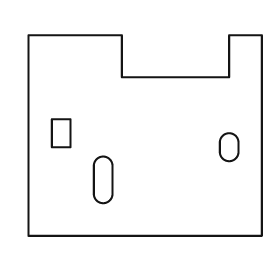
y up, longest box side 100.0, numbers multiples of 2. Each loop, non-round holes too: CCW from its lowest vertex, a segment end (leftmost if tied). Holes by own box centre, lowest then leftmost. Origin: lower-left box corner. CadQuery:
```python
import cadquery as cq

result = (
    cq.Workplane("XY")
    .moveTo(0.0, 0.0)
    .lineTo(100.0, 0.0)
    .lineTo(100.0, 86.0)
    .lineTo(86.0, 86.0)
    .lineTo(86.0, 68.0)
    .lineTo(40.0, 68.0)
    .lineTo(40.0, 86.0)
    .lineTo(0.0, 86.0)
    .close()
    .moveTo(28.0, 18.0)
    .threePointArc((32.0, 14.0), (36.0, 18.0))
    .lineTo(36.0, 30.0)
    .threePointArc((32.0, 34.0), (28.0, 30.0))
    .close()
    .moveTo(82.0, 36.0)
    .threePointArc((86.0, 32.0), (90.0, 36.0))
    .lineTo(90.0, 40.0)
    .threePointArc((86.0, 44.0), (82.0, 40.0))
    .close()
    .moveTo(10.0, 38.0)
    .lineTo(18.0, 38.0)
    .lineTo(18.0, 50.0)
    .lineTo(10.0, 50.0)
    .close()
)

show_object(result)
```